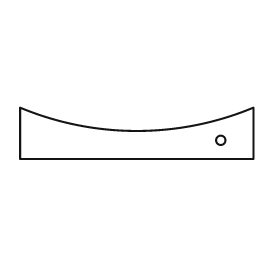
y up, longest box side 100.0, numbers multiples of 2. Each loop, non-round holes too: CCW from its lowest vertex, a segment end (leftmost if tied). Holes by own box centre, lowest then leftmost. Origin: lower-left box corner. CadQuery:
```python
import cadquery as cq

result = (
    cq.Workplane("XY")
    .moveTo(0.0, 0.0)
    .lineTo(100.0, 0.0)
    .lineTo(100.0, 22.0)
    .threePointArc((50.0, 12.0), (0.0, 22.0))
    .close()
    .moveTo(86.0, 8.0)
    .circle(2.0)
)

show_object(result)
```